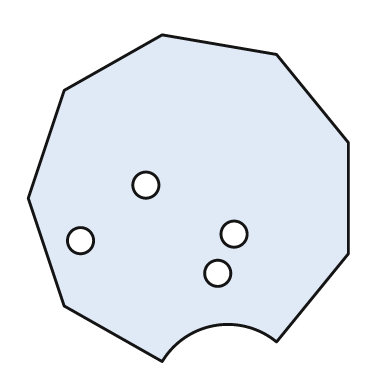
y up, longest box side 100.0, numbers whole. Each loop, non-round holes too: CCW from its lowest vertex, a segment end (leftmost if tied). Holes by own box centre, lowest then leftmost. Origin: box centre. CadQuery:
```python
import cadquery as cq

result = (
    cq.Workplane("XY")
    .moveTo(-8.0, -50.0)
    .threePointArc((8.0, -39.0), (27.0, -44.0))
    .lineTo(49.0, -17.0)
    .lineTo(49.0, 17.0)
    .lineTo(27.0, 44.0)
    .lineTo(-8.0, 50.0)
    .lineTo(-38.0, 33.0)
    .lineTo(-49.0, 0.0)
    .lineTo(-38.0, -33.0)
    .close()
    .moveTo(9.0, -23.0)
    .circle(4.0)
    .moveTo(-33.0, -13.0)
    .circle(4.0)
    .moveTo(14.0, -11.0)
    .circle(4.0)
    .moveTo(-13.0, 4.0)
    .circle(4.0)
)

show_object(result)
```